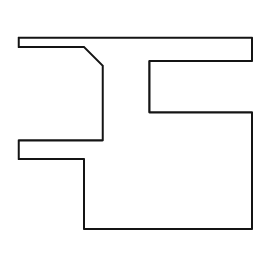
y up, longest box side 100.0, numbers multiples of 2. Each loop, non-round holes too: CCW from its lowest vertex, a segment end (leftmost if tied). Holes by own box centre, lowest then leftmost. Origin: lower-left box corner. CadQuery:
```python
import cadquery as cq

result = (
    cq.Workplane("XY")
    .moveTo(28.0, 0.0)
    .lineTo(100.0, 0.0)
    .lineTo(100.0, 50.0)
    .lineTo(56.0, 50.0)
    .lineTo(56.0, 72.0)
    .lineTo(100.0, 72.0)
    .lineTo(100.0, 82.0)
    .lineTo(0.0, 82.0)
    .lineTo(0.0, 78.0)
    .lineTo(28.0, 78.0)
    .lineTo(36.0, 70.0)
    .lineTo(36.0, 38.0)
    .lineTo(0.0, 38.0)
    .lineTo(0.0, 30.0)
    .lineTo(28.0, 30.0)
    .close()
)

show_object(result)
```